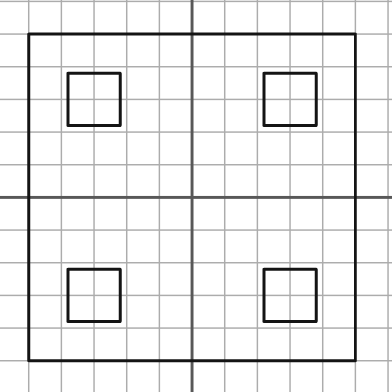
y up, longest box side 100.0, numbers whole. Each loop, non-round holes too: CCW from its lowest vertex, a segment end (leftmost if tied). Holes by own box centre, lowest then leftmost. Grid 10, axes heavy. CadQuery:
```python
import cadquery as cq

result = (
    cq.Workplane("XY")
    .moveTo(-50.0, -50.0)
    .lineTo(50.0, -50.0)
    .lineTo(50.0, 50.0)
    .lineTo(-50.0, 50.0)
    .close()
    .moveTo(-38.0, -38.0)
    .lineTo(-22.0, -38.0)
    .lineTo(-22.0, -22.0)
    .lineTo(-38.0, -22.0)
    .close()
    .moveTo(22.0, -38.0)
    .lineTo(38.0, -38.0)
    .lineTo(38.0, -22.0)
    .lineTo(22.0, -22.0)
    .close()
    .moveTo(-38.0, 22.0)
    .lineTo(-22.0, 22.0)
    .lineTo(-22.0, 38.0)
    .lineTo(-38.0, 38.0)
    .close()
    .moveTo(22.0, 22.0)
    .lineTo(38.0, 22.0)
    .lineTo(38.0, 38.0)
    .lineTo(22.0, 38.0)
    .close()
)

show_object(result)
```